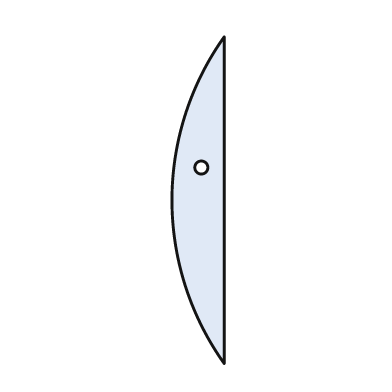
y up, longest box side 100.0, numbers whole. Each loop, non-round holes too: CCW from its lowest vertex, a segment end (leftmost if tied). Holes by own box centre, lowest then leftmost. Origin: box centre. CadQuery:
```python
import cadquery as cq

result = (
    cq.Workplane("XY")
    .moveTo(8.0, -50.0)
    .lineTo(8.0, 50.0)
    .threePointArc((-8.0, 0.0), (8.0, -50.0))
    .close()
    .moveTo(1.0, 10.0)
    .circle(2.0)
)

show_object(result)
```